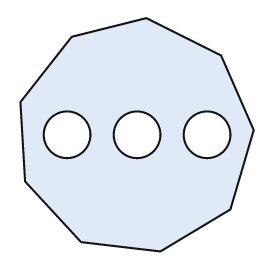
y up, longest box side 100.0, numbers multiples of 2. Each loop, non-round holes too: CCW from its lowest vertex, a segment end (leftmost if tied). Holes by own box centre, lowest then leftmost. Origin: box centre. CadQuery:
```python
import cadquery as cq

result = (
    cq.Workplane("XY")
    .moveTo(10.0, -50.0)
    .lineTo(40.0, -32.0)
    .lineTo(50.0, 2.0)
    .lineTo(36.0, 34.0)
    .lineTo(4.0, 50.0)
    .lineTo(-28.0, 42.0)
    .lineTo(-50.0, 14.0)
    .lineTo(-48.0, -20.0)
    .lineTo(-24.0, -46.0)
    .close()
    .moveTo(-30.0, 0.0)
    .circle(10.0)
    .moveTo(0.0, 0.0)
    .circle(10.0)
    .moveTo(30.0, 0.0)
    .circle(10.0)
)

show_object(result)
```